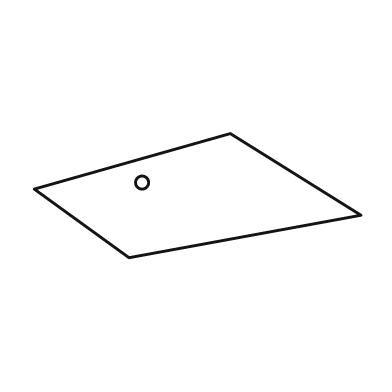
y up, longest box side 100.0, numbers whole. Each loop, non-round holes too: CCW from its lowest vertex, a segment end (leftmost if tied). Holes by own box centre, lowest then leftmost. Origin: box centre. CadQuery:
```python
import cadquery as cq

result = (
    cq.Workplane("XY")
    .moveTo(-21.0, -19.0)
    .lineTo(50.0, -6.0)
    .lineTo(10.0, 19.0)
    .lineTo(-50.0, 2.0)
    .close()
    .moveTo(-17.0, 4.0)
    .circle(2.0)
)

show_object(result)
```